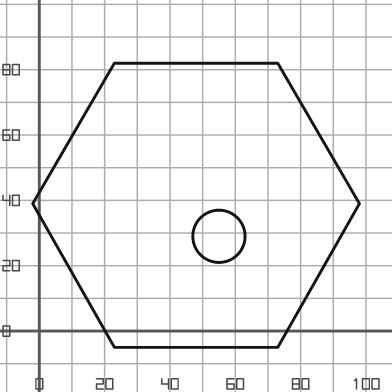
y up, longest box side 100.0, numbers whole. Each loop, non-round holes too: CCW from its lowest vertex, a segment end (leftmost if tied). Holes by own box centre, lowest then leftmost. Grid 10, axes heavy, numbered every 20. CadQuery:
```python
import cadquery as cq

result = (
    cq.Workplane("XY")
    .moveTo(23.0, -5.0)
    .lineTo(73.0, -5.0)
    .lineTo(98.0, 39.0)
    .lineTo(73.0, 82.0)
    .lineTo(23.0, 82.0)
    .lineTo(-2.0, 39.0)
    .close()
    .moveTo(55.0, 29.0)
    .circle(8.0)
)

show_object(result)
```